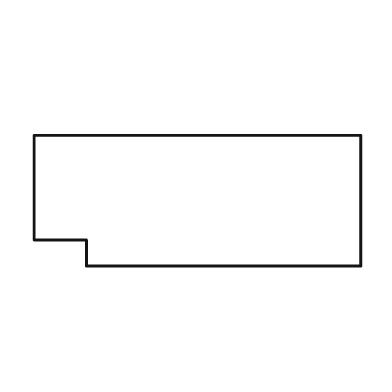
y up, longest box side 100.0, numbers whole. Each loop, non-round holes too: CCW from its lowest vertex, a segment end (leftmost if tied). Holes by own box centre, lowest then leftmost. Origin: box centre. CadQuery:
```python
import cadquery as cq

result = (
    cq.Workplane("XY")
    .moveTo(-34.0, -20.0)
    .lineTo(50.0, -20.0)
    .lineTo(50.0, 20.0)
    .lineTo(-50.0, 20.0)
    .lineTo(-50.0, -12.0)
    .lineTo(-34.0, -12.0)
    .close()
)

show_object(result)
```